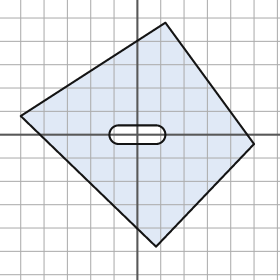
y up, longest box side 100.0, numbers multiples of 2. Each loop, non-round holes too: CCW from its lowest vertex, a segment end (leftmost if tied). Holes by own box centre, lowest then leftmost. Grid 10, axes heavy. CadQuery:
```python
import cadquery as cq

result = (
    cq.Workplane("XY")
    .moveTo(8.0, -48.0)
    .lineTo(50.0, -4.0)
    .lineTo(12.0, 48.0)
    .lineTo(-50.0, 8.0)
    .close()
    .moveTo(-8.0, -4.0)
    .lineTo(8.0, -4.0)
    .threePointArc((12.0, 0.0), (8.0, 4.0))
    .lineTo(-8.0, 4.0)
    .threePointArc((-12.0, 0.0), (-8.0, -4.0))
    .close()
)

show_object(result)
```